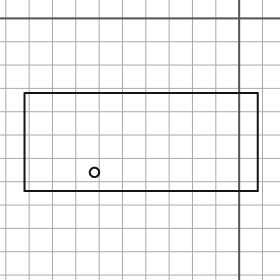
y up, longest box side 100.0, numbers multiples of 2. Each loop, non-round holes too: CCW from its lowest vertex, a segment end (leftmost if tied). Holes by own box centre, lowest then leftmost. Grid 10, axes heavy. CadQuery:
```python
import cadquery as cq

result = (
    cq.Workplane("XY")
    .moveTo(-92.0, -74.0)
    .lineTo(8.0, -74.0)
    .lineTo(8.0, -32.0)
    .lineTo(-92.0, -32.0)
    .close()
    .moveTo(-62.0, -66.0)
    .circle(2.0)
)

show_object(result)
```